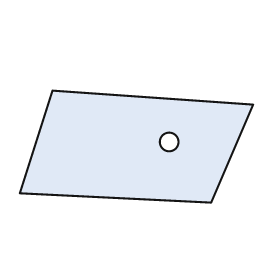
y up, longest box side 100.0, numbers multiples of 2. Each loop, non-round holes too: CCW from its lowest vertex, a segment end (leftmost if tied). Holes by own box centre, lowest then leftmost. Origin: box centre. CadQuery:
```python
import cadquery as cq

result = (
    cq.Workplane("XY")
    .moveTo(32.0, -24.0)
    .lineTo(50.0, 18.0)
    .lineTo(-36.0, 24.0)
    .lineTo(-50.0, -20.0)
    .close()
    .moveTo(14.0, 2.0)
    .circle(4.0)
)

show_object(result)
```